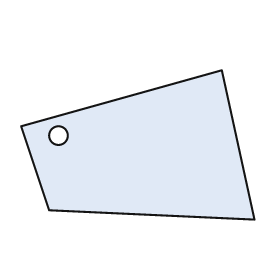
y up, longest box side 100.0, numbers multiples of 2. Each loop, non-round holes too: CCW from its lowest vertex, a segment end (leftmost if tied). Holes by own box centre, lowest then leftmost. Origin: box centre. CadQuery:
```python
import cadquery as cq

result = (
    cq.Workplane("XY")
    .moveTo(50.0, -32.0)
    .lineTo(36.0, 32.0)
    .lineTo(-50.0, 8.0)
    .lineTo(-38.0, -28.0)
    .close()
    .moveTo(-34.0, 4.0)
    .circle(4.0)
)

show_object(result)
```